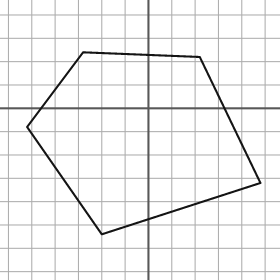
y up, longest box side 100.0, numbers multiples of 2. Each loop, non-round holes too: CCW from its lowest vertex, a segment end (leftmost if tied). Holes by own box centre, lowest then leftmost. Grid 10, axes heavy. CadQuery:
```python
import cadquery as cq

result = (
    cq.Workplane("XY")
    .moveTo(-20.0, -54.0)
    .lineTo(48.0, -32.0)
    .lineTo(22.0, 22.0)
    .lineTo(-28.0, 24.0)
    .lineTo(-52.0, -8.0)
    .close()
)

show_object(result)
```